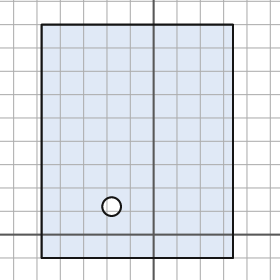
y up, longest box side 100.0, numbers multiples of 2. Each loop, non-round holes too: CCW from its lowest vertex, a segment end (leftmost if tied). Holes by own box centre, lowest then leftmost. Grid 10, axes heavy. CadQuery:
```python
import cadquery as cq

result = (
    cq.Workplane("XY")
    .moveTo(-48.0, -10.0)
    .lineTo(34.0, -10.0)
    .lineTo(34.0, 90.0)
    .lineTo(-48.0, 90.0)
    .close()
    .moveTo(-18.0, 12.0)
    .circle(4.0)
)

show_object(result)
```